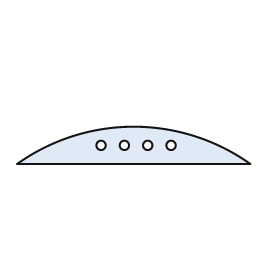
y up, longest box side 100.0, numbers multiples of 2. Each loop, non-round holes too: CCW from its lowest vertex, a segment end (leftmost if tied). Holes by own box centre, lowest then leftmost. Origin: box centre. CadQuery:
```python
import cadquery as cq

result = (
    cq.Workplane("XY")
    .moveTo(-50.0, -8.0)
    .lineTo(50.0, -8.0)
    .threePointArc((0.0, 8.0), (-50.0, -8.0))
    .close()
    .moveTo(-14.0, 0.0)
    .circle(2.0)
    .moveTo(-4.0, 0.0)
    .circle(2.0)
    .moveTo(6.0, 0.0)
    .circle(2.0)
    .moveTo(16.0, 0.0)
    .circle(2.0)
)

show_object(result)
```